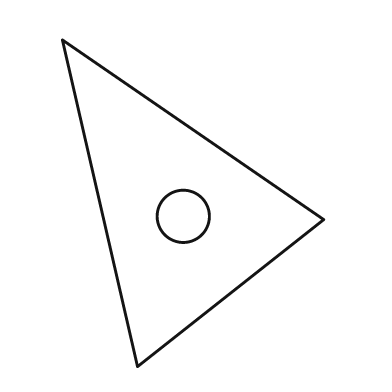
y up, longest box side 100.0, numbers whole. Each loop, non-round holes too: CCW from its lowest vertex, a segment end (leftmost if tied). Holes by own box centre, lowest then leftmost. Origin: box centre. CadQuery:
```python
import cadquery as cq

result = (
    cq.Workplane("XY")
    .moveTo(-17.0, -50.0)
    .lineTo(40.0, -5.0)
    .lineTo(-40.0, 50.0)
    .close()
    .moveTo(-3.0, -4.0)
    .circle(8.0)
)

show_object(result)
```